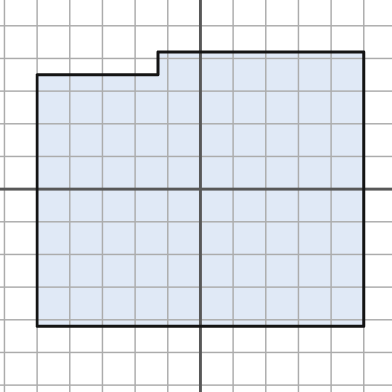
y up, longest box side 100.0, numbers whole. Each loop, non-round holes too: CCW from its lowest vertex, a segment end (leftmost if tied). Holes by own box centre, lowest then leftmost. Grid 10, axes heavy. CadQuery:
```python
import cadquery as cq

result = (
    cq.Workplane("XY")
    .moveTo(-50.0, -42.0)
    .lineTo(50.0, -42.0)
    .lineTo(50.0, 42.0)
    .lineTo(-13.0, 42.0)
    .lineTo(-13.0, 35.0)
    .lineTo(-50.0, 35.0)
    .close()
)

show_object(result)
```